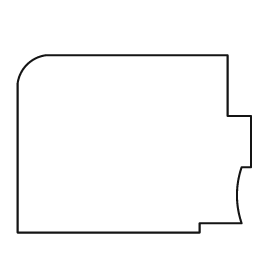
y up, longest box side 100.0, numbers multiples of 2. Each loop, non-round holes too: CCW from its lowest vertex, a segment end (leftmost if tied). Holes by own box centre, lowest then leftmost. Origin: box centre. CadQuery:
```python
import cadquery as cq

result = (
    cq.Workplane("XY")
    .moveTo(-50.0, -38.0)
    .lineTo(28.0, -38.0)
    .lineTo(28.0, -34.0)
    .lineTo(46.0, -34.0)
    .threePointArc((44.0, -22.0), (46.0, -10.0))
    .lineTo(50.0, -10.0)
    .lineTo(50.0, 12.0)
    .lineTo(40.0, 12.0)
    .lineTo(40.0, 38.0)
    .lineTo(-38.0, 38.0)
    .threePointArc((-46.0, 34.0), (-50.0, 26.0))
    .close()
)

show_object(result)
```